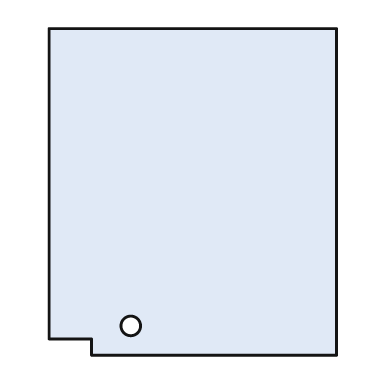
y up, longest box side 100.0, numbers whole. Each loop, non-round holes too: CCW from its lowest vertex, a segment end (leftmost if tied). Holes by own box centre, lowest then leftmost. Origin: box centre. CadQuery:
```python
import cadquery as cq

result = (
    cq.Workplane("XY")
    .moveTo(-31.0, -50.0)
    .lineTo(44.0, -50.0)
    .lineTo(44.0, 50.0)
    .lineTo(-44.0, 50.0)
    .lineTo(-44.0, -45.0)
    .lineTo(-31.0, -45.0)
    .close()
    .moveTo(-19.0, -41.0)
    .circle(3.0)
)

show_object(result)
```